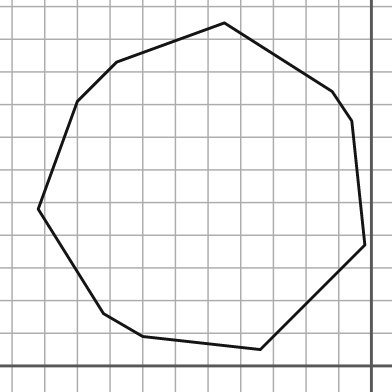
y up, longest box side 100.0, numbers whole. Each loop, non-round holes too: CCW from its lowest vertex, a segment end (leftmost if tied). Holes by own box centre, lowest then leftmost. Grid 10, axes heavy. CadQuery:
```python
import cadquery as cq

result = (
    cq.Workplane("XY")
    .moveTo(-34.0, 5.0)
    .lineTo(-2.0, 37.0)
    .lineTo(-6.0, 75.0)
    .lineTo(-12.0, 84.0)
    .lineTo(-45.0, 105.0)
    .lineTo(-78.0, 93.0)
    .lineTo(-90.0, 81.0)
    .lineTo(-102.0, 48.0)
    .lineTo(-82.0, 16.0)
    .lineTo(-70.0, 9.0)
    .close()
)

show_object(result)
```